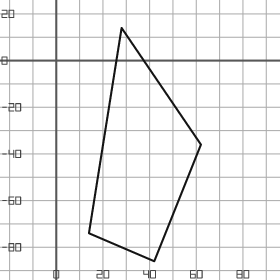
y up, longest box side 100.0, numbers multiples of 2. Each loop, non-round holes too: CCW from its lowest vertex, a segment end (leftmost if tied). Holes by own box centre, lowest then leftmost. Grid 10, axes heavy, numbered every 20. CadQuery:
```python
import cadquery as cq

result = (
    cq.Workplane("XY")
    .moveTo(42.0, -86.0)
    .lineTo(62.0, -36.0)
    .lineTo(28.0, 14.0)
    .lineTo(14.0, -74.0)
    .close()
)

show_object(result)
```